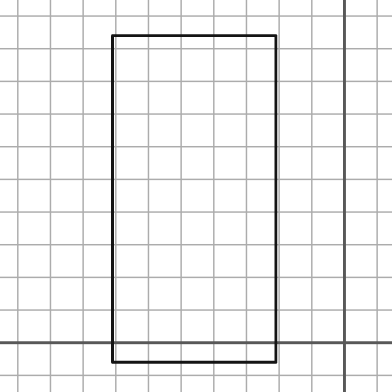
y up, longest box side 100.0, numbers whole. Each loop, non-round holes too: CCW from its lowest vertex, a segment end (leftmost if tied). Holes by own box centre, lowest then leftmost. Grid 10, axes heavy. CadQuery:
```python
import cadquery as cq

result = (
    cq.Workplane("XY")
    .moveTo(-71.0, -6.0)
    .lineTo(-21.0, -6.0)
    .lineTo(-21.0, 94.0)
    .lineTo(-71.0, 94.0)
    .close()
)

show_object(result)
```